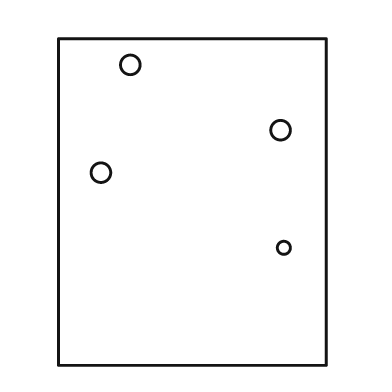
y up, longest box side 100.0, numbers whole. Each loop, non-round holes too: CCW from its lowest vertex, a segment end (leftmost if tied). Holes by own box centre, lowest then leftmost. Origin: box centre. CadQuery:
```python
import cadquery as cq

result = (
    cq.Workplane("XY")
    .moveTo(-41.0, -50.0)
    .lineTo(41.0, -50.0)
    .lineTo(41.0, 50.0)
    .lineTo(-41.0, 50.0)
    .close()
    .moveTo(28.0, -14.0)
    .circle(2.0)
    .moveTo(-28.0, 9.0)
    .circle(3.0)
    .moveTo(27.0, 22.0)
    .circle(3.0)
    .moveTo(-19.0, 42.0)
    .circle(3.0)
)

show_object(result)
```